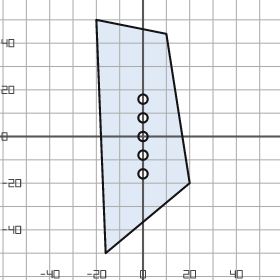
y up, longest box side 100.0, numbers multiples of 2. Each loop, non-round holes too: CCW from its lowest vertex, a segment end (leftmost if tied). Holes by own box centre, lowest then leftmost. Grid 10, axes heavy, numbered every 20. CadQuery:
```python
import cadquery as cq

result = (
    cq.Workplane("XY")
    .moveTo(-16.0, -50.0)
    .lineTo(20.0, -20.0)
    .lineTo(10.0, 44.0)
    .lineTo(-20.0, 50.0)
    .close()
    .moveTo(0.0, -16.0)
    .circle(2.0)
    .moveTo(0.0, -8.0)
    .circle(2.0)
    .moveTo(0.0, 0.0)
    .circle(2.0)
    .moveTo(0.0, 8.0)
    .circle(2.0)
    .moveTo(0.0, 16.0)
    .circle(2.0)
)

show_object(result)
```